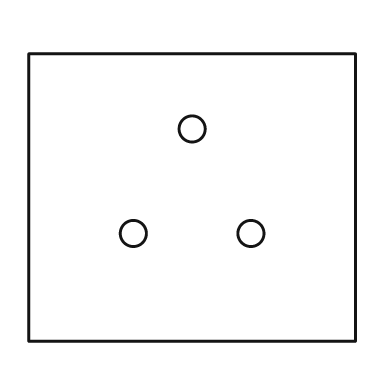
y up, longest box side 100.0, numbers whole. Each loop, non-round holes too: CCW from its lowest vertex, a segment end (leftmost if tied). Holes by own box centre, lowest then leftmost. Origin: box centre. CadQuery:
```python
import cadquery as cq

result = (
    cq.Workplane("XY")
    .moveTo(-50.0, -44.0)
    .lineTo(50.0, -44.0)
    .lineTo(50.0, 44.0)
    .lineTo(-50.0, 44.0)
    .close()
    .moveTo(-18.0, -11.0)
    .circle(4.0)
    .moveTo(18.0, -11.0)
    .circle(4.0)
    .moveTo(0.0, 21.0)
    .circle(4.0)
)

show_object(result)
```